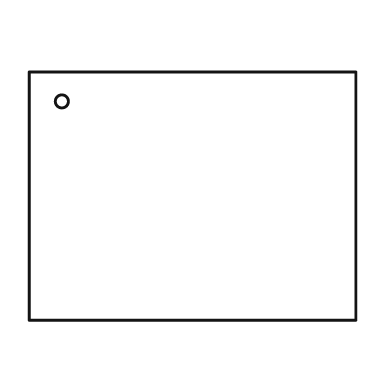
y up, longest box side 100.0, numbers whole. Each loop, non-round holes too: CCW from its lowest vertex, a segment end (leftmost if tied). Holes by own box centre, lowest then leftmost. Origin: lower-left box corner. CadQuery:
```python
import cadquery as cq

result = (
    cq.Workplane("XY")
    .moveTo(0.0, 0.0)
    .lineTo(100.0, 0.0)
    .lineTo(100.0, 76.0)
    .lineTo(0.0, 76.0)
    .close()
    .moveTo(10.0, 67.0)
    .circle(2.0)
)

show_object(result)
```